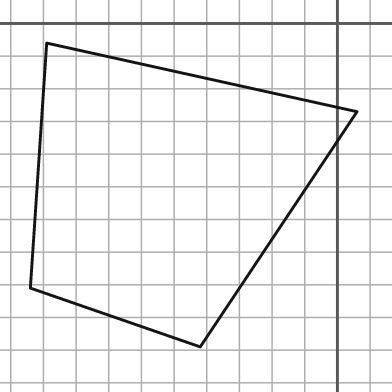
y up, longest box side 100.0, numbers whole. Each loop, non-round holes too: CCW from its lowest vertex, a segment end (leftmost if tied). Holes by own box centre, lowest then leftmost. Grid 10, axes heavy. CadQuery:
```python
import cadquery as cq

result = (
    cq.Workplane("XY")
    .moveTo(-42.0, -99.0)
    .lineTo(6.0, -27.0)
    .lineTo(-89.0, -6.0)
    .lineTo(-94.0, -81.0)
    .close()
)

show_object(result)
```